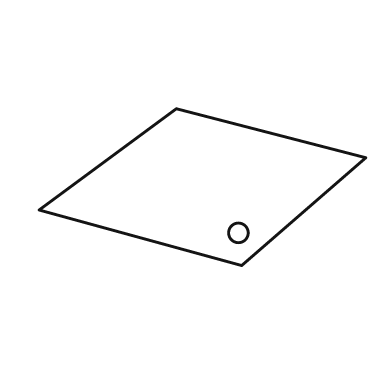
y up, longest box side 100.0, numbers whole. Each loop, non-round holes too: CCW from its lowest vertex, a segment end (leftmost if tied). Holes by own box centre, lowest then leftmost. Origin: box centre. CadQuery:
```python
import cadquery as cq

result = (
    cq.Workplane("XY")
    .moveTo(12.0, -24.0)
    .lineTo(50.0, 9.0)
    .lineTo(-8.0, 24.0)
    .lineTo(-50.0, -7.0)
    .close()
    .moveTo(11.0, -14.0)
    .circle(3.0)
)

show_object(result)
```